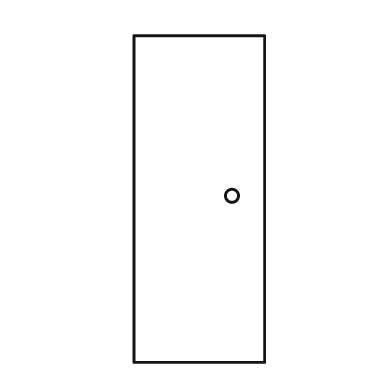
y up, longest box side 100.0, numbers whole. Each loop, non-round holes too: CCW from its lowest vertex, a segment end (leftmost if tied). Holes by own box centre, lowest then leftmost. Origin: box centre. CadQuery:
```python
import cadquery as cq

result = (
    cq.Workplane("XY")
    .moveTo(-20.0, -50.0)
    .lineTo(20.0, -50.0)
    .lineTo(20.0, 50.0)
    .lineTo(-20.0, 50.0)
    .close()
    .moveTo(10.0, 1.0)
    .circle(2.0)
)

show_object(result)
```